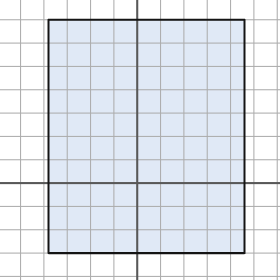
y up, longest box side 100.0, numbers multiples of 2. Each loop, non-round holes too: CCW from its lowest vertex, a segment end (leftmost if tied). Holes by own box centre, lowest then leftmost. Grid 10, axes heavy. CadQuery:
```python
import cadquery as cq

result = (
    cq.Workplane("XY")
    .moveTo(-38.0, -30.0)
    .lineTo(46.0, -30.0)
    .lineTo(46.0, 70.0)
    .lineTo(-38.0, 70.0)
    .close()
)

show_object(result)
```